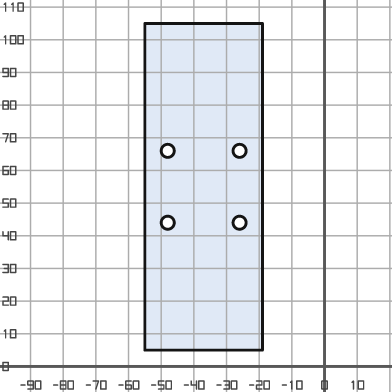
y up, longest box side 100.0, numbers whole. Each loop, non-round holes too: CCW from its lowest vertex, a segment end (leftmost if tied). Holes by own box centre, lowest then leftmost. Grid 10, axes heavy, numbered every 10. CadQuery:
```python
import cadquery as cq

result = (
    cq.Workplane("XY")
    .moveTo(-55.0, 5.0)
    .lineTo(-19.0, 5.0)
    .lineTo(-19.0, 105.0)
    .lineTo(-55.0, 105.0)
    .close()
    .moveTo(-48.0, 44.0)
    .circle(2.0)
    .moveTo(-26.0, 44.0)
    .circle(2.0)
    .moveTo(-48.0, 66.0)
    .circle(2.0)
    .moveTo(-26.0, 66.0)
    .circle(2.0)
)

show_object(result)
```